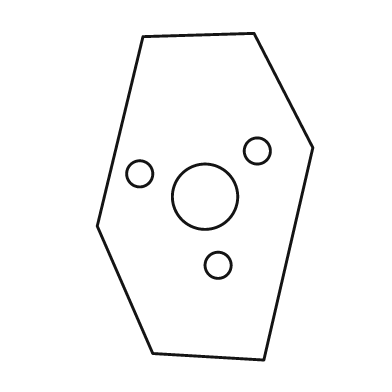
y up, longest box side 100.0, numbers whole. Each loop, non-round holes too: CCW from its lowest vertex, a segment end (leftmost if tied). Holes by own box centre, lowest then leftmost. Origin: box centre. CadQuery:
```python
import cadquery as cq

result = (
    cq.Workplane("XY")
    .moveTo(18.0, -50.0)
    .lineTo(33.0, 15.0)
    .lineTo(15.0, 50.0)
    .lineTo(-19.0, 49.0)
    .lineTo(-33.0, -9.0)
    .lineTo(-16.0, -48.0)
    .close()
    .moveTo(4.0, -21.0)
    .circle(4.0)
    .moveTo(0.0, 0.0)
    .circle(10.0)
    .moveTo(-20.0, 7.0)
    .circle(4.0)
    .moveTo(16.0, 14.0)
    .circle(4.0)
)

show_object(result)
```